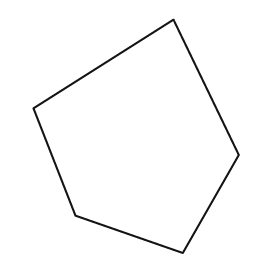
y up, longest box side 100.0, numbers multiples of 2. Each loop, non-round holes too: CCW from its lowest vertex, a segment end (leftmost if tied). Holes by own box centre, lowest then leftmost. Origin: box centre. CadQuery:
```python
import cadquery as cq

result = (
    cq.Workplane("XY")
    .moveTo(20.0, -50.0)
    .lineTo(44.0, -8.0)
    .lineTo(16.0, 50.0)
    .lineTo(-44.0, 12.0)
    .lineTo(-26.0, -34.0)
    .close()
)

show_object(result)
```